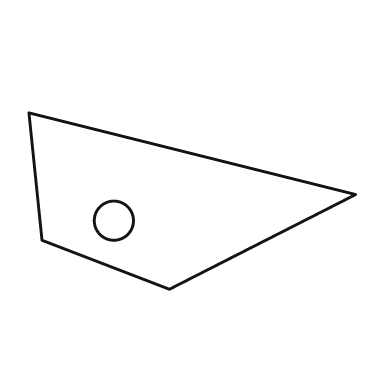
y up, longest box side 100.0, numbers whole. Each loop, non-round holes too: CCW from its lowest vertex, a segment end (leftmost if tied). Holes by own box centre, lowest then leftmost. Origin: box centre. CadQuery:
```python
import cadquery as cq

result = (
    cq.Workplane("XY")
    .moveTo(-7.0, -27.0)
    .lineTo(50.0, 2.0)
    .lineTo(-50.0, 27.0)
    .lineTo(-46.0, -12.0)
    .close()
    .moveTo(-24.0, -6.0)
    .circle(6.0)
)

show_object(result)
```